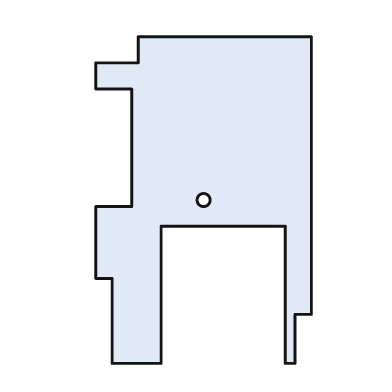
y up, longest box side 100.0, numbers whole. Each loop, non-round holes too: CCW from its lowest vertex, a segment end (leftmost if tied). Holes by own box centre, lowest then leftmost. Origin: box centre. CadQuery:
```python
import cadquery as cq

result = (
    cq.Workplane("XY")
    .moveTo(-28.0, -50.0)
    .lineTo(-13.0, -50.0)
    .lineTo(-13.0, -8.0)
    .lineTo(25.0, -8.0)
    .lineTo(25.0, -50.0)
    .lineTo(28.0, -50.0)
    .lineTo(28.0, -35.0)
    .lineTo(33.0, -35.0)
    .lineTo(33.0, 50.0)
    .lineTo(-20.0, 50.0)
    .lineTo(-20.0, 42.0)
    .lineTo(-33.0, 42.0)
    .lineTo(-33.0, 34.0)
    .lineTo(-22.0, 34.0)
    .lineTo(-22.0, -2.0)
    .lineTo(-33.0, -2.0)
    .lineTo(-33.0, -24.0)
    .lineTo(-28.0, -24.0)
    .close()
    .moveTo(0.0, 0.0)
    .circle(2.0)
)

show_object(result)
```